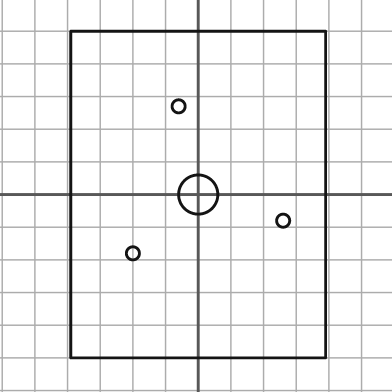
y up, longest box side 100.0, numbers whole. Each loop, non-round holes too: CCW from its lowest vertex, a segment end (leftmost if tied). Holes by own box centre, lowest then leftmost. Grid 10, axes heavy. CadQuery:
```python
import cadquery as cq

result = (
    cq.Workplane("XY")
    .moveTo(-39.0, -50.0)
    .lineTo(39.0, -50.0)
    .lineTo(39.0, 50.0)
    .lineTo(-39.0, 50.0)
    .close()
    .moveTo(-20.0, -18.0)
    .circle(2.0)
    .moveTo(26.0, -8.0)
    .circle(2.0)
    .moveTo(0.0, 0.0)
    .circle(6.0)
    .moveTo(-6.0, 27.0)
    .circle(2.0)
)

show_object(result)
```